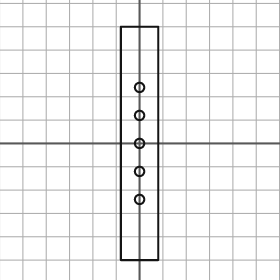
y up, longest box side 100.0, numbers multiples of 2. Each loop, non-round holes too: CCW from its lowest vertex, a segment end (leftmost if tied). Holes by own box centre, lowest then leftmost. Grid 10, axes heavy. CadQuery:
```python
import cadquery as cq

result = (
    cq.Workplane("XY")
    .moveTo(-8.0, -50.0)
    .lineTo(8.0, -50.0)
    .lineTo(8.0, 50.0)
    .lineTo(-8.0, 50.0)
    .close()
    .moveTo(0.0, -24.0)
    .circle(2.0)
    .moveTo(0.0, -12.0)
    .circle(2.0)
    .moveTo(0.0, 0.0)
    .circle(2.0)
    .moveTo(0.0, 12.0)
    .circle(2.0)
    .moveTo(0.0, 24.0)
    .circle(2.0)
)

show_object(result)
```